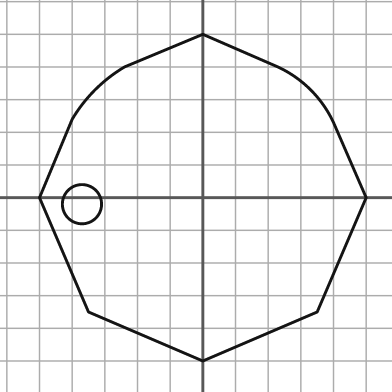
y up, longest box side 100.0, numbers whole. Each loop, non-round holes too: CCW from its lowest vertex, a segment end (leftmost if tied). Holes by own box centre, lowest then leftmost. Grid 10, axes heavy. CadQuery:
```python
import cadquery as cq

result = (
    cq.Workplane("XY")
    .moveTo(0.0, -50.0)
    .lineTo(35.0, -35.0)
    .lineTo(50.0, 0.0)
    .lineTo(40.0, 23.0)
    .threePointArc((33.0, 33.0), (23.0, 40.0))
    .lineTo(0.0, 50.0)
    .lineTo(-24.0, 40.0)
    .threePointArc((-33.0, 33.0), (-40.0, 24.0))
    .lineTo(-50.0, 0.0)
    .lineTo(-35.0, -35.0)
    .close()
    .moveTo(-37.0, -2.0)
    .circle(6.0)
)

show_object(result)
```